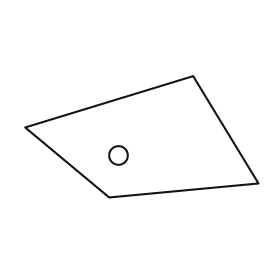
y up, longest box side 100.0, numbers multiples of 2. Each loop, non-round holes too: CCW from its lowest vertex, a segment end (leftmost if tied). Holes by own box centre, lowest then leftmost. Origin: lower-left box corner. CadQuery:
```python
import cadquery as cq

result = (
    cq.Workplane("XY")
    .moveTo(36.0, 0.0)
    .lineTo(100.0, 6.0)
    .lineTo(72.0, 52.0)
    .lineTo(0.0, 30.0)
    .close()
    .moveTo(40.0, 18.0)
    .circle(4.0)
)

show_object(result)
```